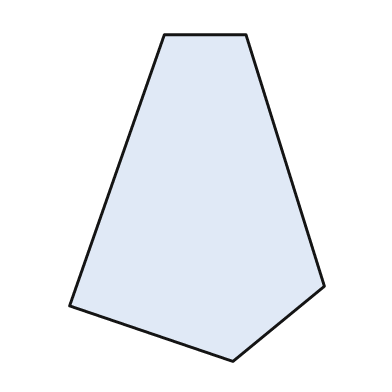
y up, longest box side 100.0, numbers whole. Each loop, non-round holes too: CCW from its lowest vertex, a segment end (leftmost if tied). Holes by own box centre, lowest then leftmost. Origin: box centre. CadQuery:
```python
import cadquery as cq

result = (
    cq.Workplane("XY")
    .moveTo(11.0, -50.0)
    .lineTo(39.0, -27.0)
    .lineTo(15.0, 50.0)
    .lineTo(-10.0, 50.0)
    .lineTo(-39.0, -33.0)
    .close()
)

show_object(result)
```